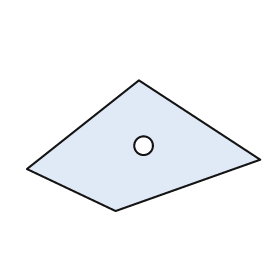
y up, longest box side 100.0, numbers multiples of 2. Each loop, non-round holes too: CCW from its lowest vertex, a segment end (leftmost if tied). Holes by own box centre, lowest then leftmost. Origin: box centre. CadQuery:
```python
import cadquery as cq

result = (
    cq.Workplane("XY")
    .moveTo(-12.0, -28.0)
    .lineTo(50.0, -6.0)
    .lineTo(-2.0, 28.0)
    .lineTo(-50.0, -10.0)
    .close()
    .moveTo(0.0, 0.0)
    .circle(4.0)
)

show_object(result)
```